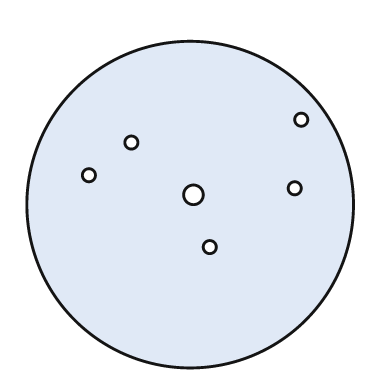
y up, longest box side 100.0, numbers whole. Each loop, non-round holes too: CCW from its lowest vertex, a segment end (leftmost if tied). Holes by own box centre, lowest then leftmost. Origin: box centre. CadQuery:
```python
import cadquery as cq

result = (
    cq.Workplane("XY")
    .moveTo(0.0, 0.0)
    .circle(50.0)
    .moveTo(6.0, -13.0)
    .circle(2.0)
    .moveTo(1.0, 3.0)
    .circle(3.0)
    .moveTo(32.0, 5.0)
    .circle(2.0)
    .moveTo(-31.0, 9.0)
    .circle(2.0)
    .moveTo(-18.0, 19.0)
    .circle(2.0)
    .moveTo(34.0, 26.0)
    .circle(2.0)
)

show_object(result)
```